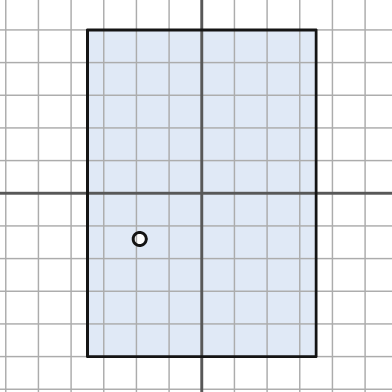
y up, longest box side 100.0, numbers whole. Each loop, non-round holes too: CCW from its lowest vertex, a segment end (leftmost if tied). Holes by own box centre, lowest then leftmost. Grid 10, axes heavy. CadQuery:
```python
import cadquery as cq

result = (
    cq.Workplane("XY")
    .moveTo(-35.0, -50.0)
    .lineTo(35.0, -50.0)
    .lineTo(35.0, 50.0)
    .lineTo(-35.0, 50.0)
    .close()
    .moveTo(-19.0, -14.0)
    .circle(2.0)
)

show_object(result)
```